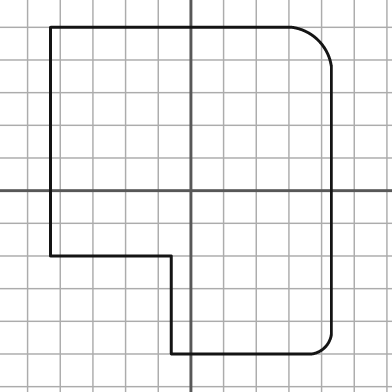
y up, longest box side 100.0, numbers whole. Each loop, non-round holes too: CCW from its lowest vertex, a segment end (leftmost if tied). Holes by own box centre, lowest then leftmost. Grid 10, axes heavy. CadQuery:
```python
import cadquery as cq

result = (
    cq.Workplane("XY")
    .moveTo(-6.0, -50.0)
    .lineTo(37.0, -50.0)
    .threePointArc((41.0, -48.0), (43.0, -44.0))
    .lineTo(43.0, 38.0)
    .threePointArc((39.0, 46.0), (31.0, 50.0))
    .lineTo(-43.0, 50.0)
    .lineTo(-43.0, -20.0)
    .lineTo(-6.0, -20.0)
    .close()
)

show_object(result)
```